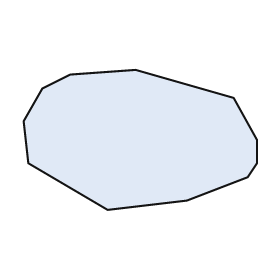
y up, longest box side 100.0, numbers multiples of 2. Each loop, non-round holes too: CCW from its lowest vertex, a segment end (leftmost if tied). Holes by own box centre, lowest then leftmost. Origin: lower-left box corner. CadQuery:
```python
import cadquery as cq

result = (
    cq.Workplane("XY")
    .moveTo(36.0, 0.0)
    .lineTo(70.0, 4.0)
    .lineTo(96.0, 14.0)
    .lineTo(100.0, 20.0)
    .lineTo(100.0, 30.0)
    .lineTo(90.0, 48.0)
    .lineTo(48.0, 60.0)
    .lineTo(20.0, 58.0)
    .lineTo(8.0, 52.0)
    .lineTo(0.0, 38.0)
    .lineTo(2.0, 20.0)
    .close()
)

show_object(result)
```